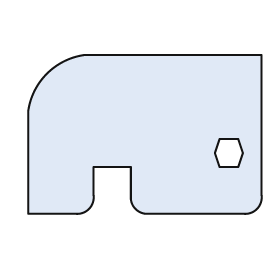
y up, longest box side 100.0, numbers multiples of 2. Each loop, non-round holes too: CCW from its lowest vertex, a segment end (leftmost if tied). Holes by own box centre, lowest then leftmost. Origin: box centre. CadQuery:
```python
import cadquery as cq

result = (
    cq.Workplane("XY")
    .moveTo(-50.0, -34.0)
    .lineTo(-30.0, -34.0)
    .threePointArc((-24.0, -32.0), (-22.0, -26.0))
    .lineTo(-22.0, -14.0)
    .lineTo(-6.0, -14.0)
    .lineTo(-6.0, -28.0)
    .threePointArc((-4.0, -32.0), (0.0, -34.0))
    .lineTo(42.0, -34.0)
    .threePointArc((48.0, -32.0), (50.0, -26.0))
    .lineTo(50.0, 34.0)
    .lineTo(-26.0, 34.0)
    .threePointArc((-42.0, 26.0), (-50.0, 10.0))
    .close()
    .moveTo(32.0, -14.0)
    .lineTo(40.0, -14.0)
    .lineTo(42.0, -8.0)
    .lineTo(40.0, -2.0)
    .lineTo(32.0, -2.0)
    .lineTo(30.0, -8.0)
    .close()
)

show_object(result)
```